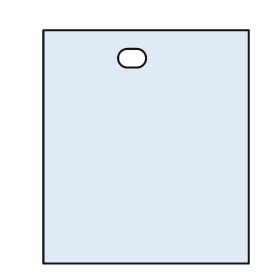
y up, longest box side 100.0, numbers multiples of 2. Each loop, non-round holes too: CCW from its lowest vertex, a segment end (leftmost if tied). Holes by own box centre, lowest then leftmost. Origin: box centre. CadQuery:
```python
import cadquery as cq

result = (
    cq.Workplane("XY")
    .moveTo(-44.0, -50.0)
    .lineTo(44.0, -50.0)
    .lineTo(44.0, 50.0)
    .lineTo(-44.0, 50.0)
    .close()
    .moveTo(-8.0, 34.0)
    .lineTo(-4.0, 34.0)
    .threePointArc((0.0, 38.0), (-4.0, 42.0))
    .lineTo(-8.0, 42.0)
    .threePointArc((-12.0, 38.0), (-8.0, 34.0))
    .close()
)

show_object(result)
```